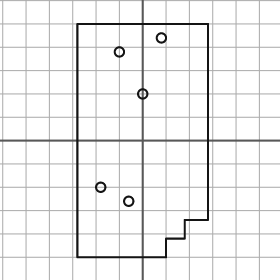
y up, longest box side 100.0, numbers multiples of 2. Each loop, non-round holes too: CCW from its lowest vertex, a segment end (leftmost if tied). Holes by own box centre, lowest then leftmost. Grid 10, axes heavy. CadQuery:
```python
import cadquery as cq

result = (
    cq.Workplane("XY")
    .moveTo(-28.0, -50.0)
    .lineTo(10.0, -50.0)
    .lineTo(10.0, -42.0)
    .lineTo(18.0, -42.0)
    .lineTo(18.0, -34.0)
    .lineTo(28.0, -34.0)
    .lineTo(28.0, 50.0)
    .lineTo(-28.0, 50.0)
    .close()
    .moveTo(-6.0, -26.0)
    .circle(2.0)
    .moveTo(-18.0, -20.0)
    .circle(2.0)
    .moveTo(0.0, 20.0)
    .circle(2.0)
    .moveTo(-10.0, 38.0)
    .circle(2.0)
    .moveTo(8.0, 44.0)
    .circle(2.0)
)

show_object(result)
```